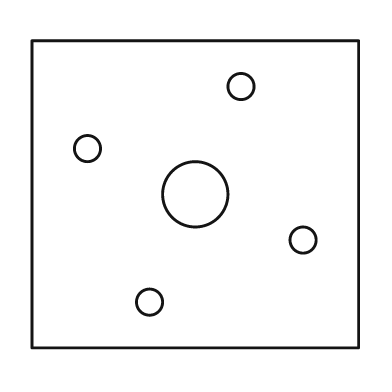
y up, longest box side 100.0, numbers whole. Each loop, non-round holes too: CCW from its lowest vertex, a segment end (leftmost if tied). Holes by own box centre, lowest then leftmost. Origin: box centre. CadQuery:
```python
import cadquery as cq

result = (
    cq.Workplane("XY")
    .moveTo(-50.0, -47.0)
    .lineTo(50.0, -47.0)
    .lineTo(50.0, 47.0)
    .lineTo(-50.0, 47.0)
    .close()
    .moveTo(-14.0, -33.0)
    .circle(4.0)
    .moveTo(33.0, -14.0)
    .circle(4.0)
    .moveTo(0.0, 0.0)
    .circle(10.0)
    .moveTo(-33.0, 14.0)
    .circle(4.0)
    .moveTo(14.0, 33.0)
    .circle(4.0)
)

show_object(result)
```